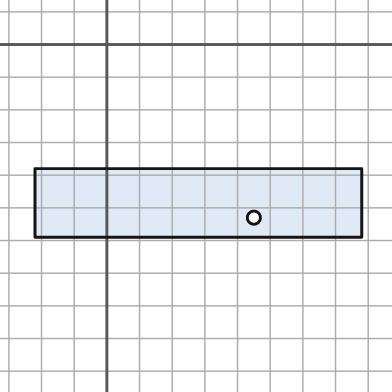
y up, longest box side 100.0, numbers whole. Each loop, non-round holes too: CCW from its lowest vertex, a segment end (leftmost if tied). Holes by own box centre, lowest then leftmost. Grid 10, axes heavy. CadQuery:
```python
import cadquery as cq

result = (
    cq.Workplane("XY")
    .moveTo(-22.0, -59.0)
    .lineTo(78.0, -59.0)
    .lineTo(78.0, -38.0)
    .lineTo(-22.0, -38.0)
    .close()
    .moveTo(45.0, -53.0)
    .circle(2.0)
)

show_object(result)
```